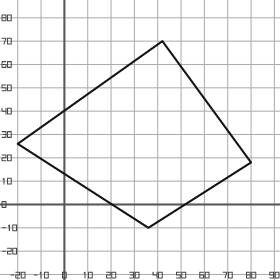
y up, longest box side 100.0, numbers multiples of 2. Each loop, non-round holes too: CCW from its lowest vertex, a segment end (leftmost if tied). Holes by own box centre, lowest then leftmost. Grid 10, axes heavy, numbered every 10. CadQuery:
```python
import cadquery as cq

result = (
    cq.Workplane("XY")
    .moveTo(36.0, -10.0)
    .lineTo(80.0, 18.0)
    .lineTo(42.0, 70.0)
    .lineTo(-20.0, 26.0)
    .close()
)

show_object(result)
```